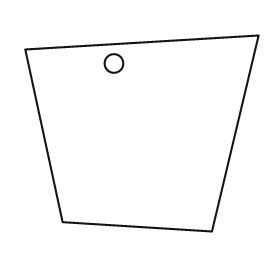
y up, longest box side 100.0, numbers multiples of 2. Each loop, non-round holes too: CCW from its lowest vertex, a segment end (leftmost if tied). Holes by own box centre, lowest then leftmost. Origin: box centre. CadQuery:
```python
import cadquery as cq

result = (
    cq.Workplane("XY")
    .moveTo(30.0, -42.0)
    .lineTo(50.0, 42.0)
    .lineTo(-50.0, 36.0)
    .lineTo(-34.0, -38.0)
    .close()
    .moveTo(-12.0, 30.0)
    .circle(4.0)
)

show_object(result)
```